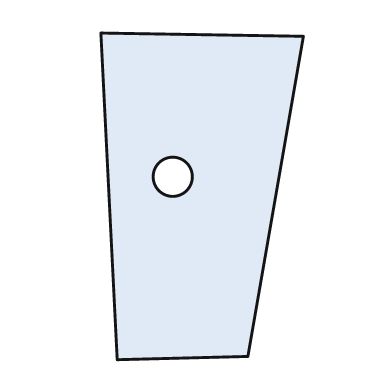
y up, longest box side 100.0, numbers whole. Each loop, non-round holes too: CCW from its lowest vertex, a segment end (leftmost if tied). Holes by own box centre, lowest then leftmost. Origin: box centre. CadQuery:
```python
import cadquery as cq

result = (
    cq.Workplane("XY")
    .moveTo(-26.0, -50.0)
    .lineTo(14.0, -49.0)
    .lineTo(31.0, 49.0)
    .lineTo(-31.0, 50.0)
    .close()
    .moveTo(-9.0, 6.0)
    .circle(6.0)
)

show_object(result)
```